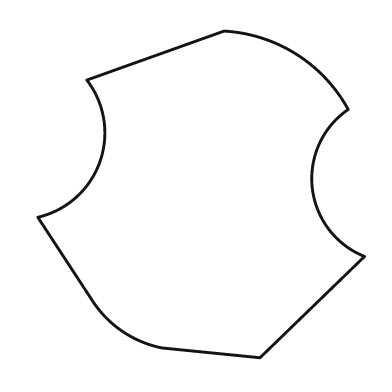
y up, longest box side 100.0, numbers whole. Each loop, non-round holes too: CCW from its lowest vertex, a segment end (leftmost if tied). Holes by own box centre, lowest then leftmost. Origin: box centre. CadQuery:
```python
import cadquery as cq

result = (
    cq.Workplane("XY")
    .moveTo(18.0, -50.0)
    .lineTo(50.0, -19.0)
    .threePointArc((34.0, 2.0), (45.0, 26.0))
    .threePointArc((29.0, 43.0), (7.0, 50.0))
    .lineTo(-35.0, 35.0)
    .threePointArc((-31.0, 10.0), (-50.0, -7.0))
    .lineTo(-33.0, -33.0)
    .threePointArc((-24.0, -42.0), (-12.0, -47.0))
    .close()
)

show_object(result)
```